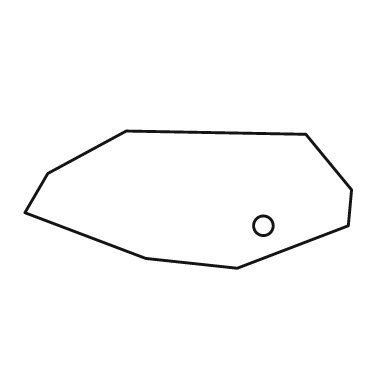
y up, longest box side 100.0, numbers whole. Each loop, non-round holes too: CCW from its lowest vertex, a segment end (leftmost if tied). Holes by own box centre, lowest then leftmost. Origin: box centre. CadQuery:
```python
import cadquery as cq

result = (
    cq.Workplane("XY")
    .moveTo(15.0, -21.0)
    .lineTo(49.0, -8.0)
    .lineTo(50.0, 3.0)
    .lineTo(36.0, 20.0)
    .lineTo(-19.0, 21.0)
    .lineTo(-43.0, 8.0)
    .lineTo(-50.0, -4.0)
    .lineTo(-13.0, -18.0)
    .close()
    .moveTo(23.0, -8.0)
    .circle(3.0)
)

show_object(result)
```